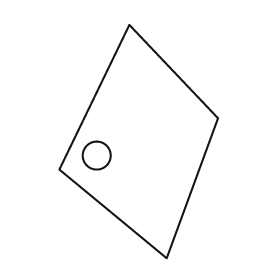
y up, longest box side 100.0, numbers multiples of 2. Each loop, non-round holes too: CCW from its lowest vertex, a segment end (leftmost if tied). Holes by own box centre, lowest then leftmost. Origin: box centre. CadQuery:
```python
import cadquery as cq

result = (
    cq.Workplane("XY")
    .moveTo(12.0, -50.0)
    .lineTo(34.0, 10.0)
    .lineTo(-4.0, 50.0)
    .lineTo(-34.0, -12.0)
    .close()
    .moveTo(-18.0, -6.0)
    .circle(6.0)
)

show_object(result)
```